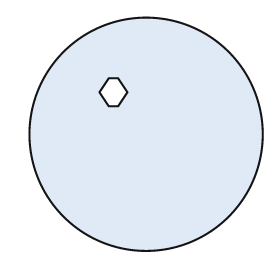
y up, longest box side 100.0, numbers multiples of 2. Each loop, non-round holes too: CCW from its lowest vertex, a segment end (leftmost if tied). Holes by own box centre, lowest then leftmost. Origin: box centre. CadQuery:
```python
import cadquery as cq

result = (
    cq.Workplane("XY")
    .moveTo(0.0, 0.0)
    .circle(50.0)
    .moveTo(-16.0, 12.0)
    .lineTo(-12.0, 12.0)
    .lineTo(-8.0, 18.0)
    .lineTo(-12.0, 24.0)
    .lineTo(-16.0, 24.0)
    .lineTo(-20.0, 18.0)
    .close()
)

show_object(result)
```